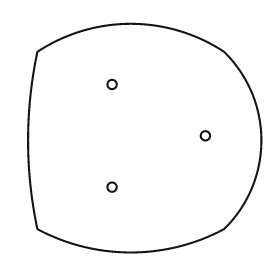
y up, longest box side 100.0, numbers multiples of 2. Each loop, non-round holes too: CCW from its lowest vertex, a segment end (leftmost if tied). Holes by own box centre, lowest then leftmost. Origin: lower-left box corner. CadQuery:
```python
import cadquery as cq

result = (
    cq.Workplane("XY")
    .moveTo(4.0, 10.0)
    .threePointArc((44.0, 0.0), (84.0, 10.0))
    .threePointArc((100.0, 48.0), (84.0, 86.0))
    .threePointArc((44.0, 98.0), (4.0, 86.0))
    .threePointArc((0.0, 48.0), (4.0, 10.0))
    .close()
    .moveTo(36.0, 28.0)
    .circle(2.0)
    .moveTo(76.0, 50.0)
    .circle(2.0)
    .moveTo(36.0, 72.0)
    .circle(2.0)
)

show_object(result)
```